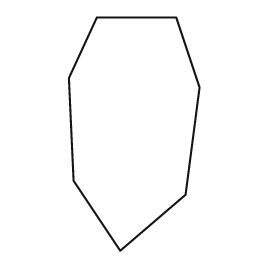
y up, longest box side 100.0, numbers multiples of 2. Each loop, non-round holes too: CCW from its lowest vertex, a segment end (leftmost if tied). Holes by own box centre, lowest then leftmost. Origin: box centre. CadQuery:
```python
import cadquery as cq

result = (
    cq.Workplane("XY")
    .moveTo(-6.0, -50.0)
    .lineTo(22.0, -26.0)
    .lineTo(28.0, 20.0)
    .lineTo(18.0, 50.0)
    .lineTo(-16.0, 50.0)
    .lineTo(-28.0, 24.0)
    .lineTo(-26.0, -20.0)
    .close()
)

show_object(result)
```